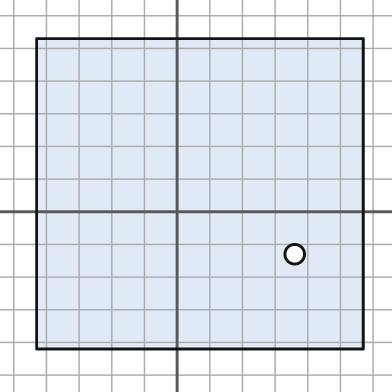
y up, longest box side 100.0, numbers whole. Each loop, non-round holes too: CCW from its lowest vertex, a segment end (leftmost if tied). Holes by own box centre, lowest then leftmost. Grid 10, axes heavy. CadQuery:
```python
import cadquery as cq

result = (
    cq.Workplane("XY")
    .moveTo(-43.0, -42.0)
    .lineTo(57.0, -42.0)
    .lineTo(57.0, 53.0)
    .lineTo(-43.0, 53.0)
    .close()
    .moveTo(36.0, -13.0)
    .circle(3.0)
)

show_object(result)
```